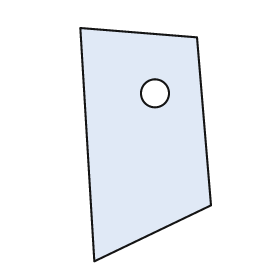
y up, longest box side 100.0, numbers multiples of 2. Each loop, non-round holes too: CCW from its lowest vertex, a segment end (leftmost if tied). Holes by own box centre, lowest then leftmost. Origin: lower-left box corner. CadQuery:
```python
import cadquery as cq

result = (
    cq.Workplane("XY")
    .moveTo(6.0, 0.0)
    .lineTo(56.0, 24.0)
    .lineTo(50.0, 96.0)
    .lineTo(0.0, 100.0)
    .close()
    .moveTo(32.0, 72.0)
    .circle(6.0)
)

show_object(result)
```